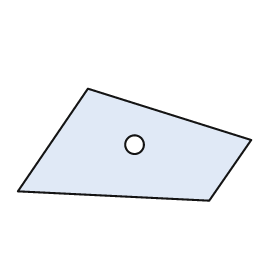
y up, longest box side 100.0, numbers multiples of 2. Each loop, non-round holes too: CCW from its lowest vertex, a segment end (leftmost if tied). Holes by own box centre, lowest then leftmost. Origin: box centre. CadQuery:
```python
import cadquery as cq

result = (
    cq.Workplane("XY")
    .moveTo(32.0, -24.0)
    .lineTo(50.0, 2.0)
    .lineTo(-20.0, 24.0)
    .lineTo(-50.0, -20.0)
    .close()
    .moveTo(0.0, 0.0)
    .circle(4.0)
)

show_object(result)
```